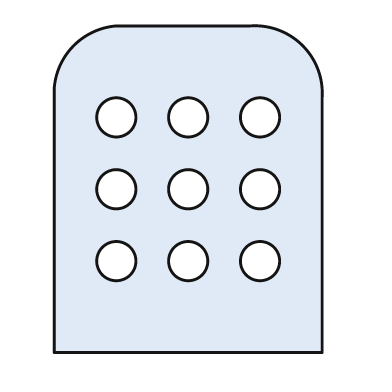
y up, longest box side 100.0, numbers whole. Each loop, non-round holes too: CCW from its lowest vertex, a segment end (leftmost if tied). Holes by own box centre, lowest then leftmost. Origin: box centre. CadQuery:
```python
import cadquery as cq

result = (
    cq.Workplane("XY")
    .moveTo(-41.0, -50.0)
    .lineTo(41.0, -50.0)
    .lineTo(41.0, 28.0)
    .threePointArc((35.0, 44.0), (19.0, 50.0))
    .lineTo(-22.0, 50.0)
    .threePointArc((-35.0, 44.0), (-41.0, 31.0))
    .close()
    .moveTo(-22.0, -22.0)
    .circle(6.0)
    .moveTo(0.0, -22.0)
    .circle(6.0)
    .moveTo(22.0, -22.0)
    .circle(6.0)
    .moveTo(-22.0, 0.0)
    .circle(6.0)
    .moveTo(0.0, 0.0)
    .circle(6.0)
    .moveTo(22.0, 0.0)
    .circle(6.0)
    .moveTo(-22.0, 22.0)
    .circle(6.0)
    .moveTo(0.0, 22.0)
    .circle(6.0)
    .moveTo(22.0, 22.0)
    .circle(6.0)
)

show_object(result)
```